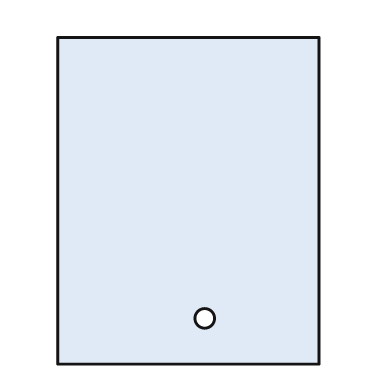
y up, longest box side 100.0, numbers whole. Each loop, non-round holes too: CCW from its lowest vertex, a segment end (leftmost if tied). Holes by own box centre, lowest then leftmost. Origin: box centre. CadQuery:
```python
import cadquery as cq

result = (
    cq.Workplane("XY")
    .moveTo(-40.0, -50.0)
    .lineTo(40.0, -50.0)
    .lineTo(40.0, 50.0)
    .lineTo(-40.0, 50.0)
    .close()
    .moveTo(5.0, -36.0)
    .circle(3.0)
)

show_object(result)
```